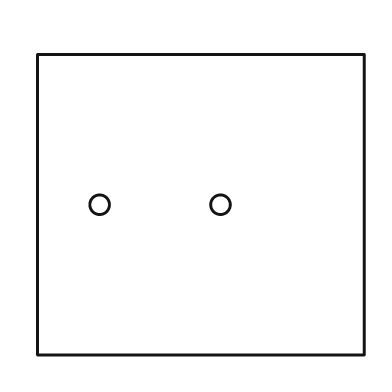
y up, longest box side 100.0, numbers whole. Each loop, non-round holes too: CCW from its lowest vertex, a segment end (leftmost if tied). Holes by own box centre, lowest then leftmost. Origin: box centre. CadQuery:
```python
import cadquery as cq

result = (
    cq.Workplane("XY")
    .moveTo(-50.0, -46.0)
    .lineTo(50.0, -46.0)
    .lineTo(50.0, 46.0)
    .lineTo(-50.0, 46.0)
    .close()
    .moveTo(-31.0, 0.0)
    .circle(3.0)
    .moveTo(6.0, 0.0)
    .circle(3.0)
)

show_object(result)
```